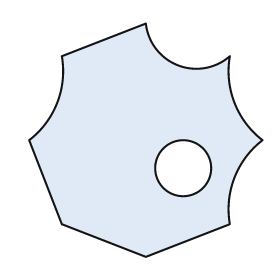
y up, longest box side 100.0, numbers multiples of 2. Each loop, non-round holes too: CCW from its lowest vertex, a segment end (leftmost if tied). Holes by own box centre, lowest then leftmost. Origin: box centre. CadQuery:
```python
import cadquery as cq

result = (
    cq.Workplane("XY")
    .moveTo(0.0, -50.0)
    .lineTo(36.0, -36.0)
    .threePointArc((38.0, -16.0), (50.0, 0.0))
    .threePointArc((38.0, 16.0), (36.0, 36.0))
    .threePointArc((14.0, 32.0), (0.0, 50.0))
    .lineTo(-36.0, 36.0)
    .threePointArc((-38.0, 16.0), (-50.0, 0.0))
    .lineTo(-36.0, -36.0)
    .close()
    .moveTo(16.0, -12.0)
    .circle(12.0)
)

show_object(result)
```